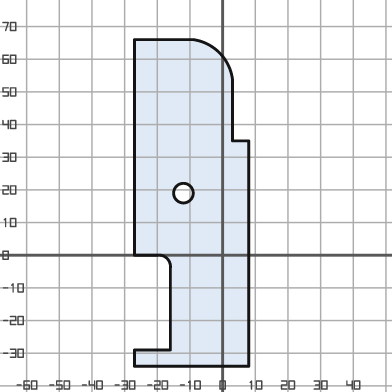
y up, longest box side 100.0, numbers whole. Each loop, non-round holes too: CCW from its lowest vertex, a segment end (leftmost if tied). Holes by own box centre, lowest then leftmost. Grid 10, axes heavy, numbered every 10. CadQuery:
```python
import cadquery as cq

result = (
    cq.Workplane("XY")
    .moveTo(-27.0, -34.0)
    .lineTo(8.0, -34.0)
    .lineTo(8.0, 35.0)
    .lineTo(3.0, 35.0)
    .lineTo(3.0, 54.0)
    .threePointArc((-1.0, 62.0), (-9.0, 66.0))
    .lineTo(-27.0, 66.0)
    .lineTo(-27.0, 0.0)
    .lineTo(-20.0, 0.0)
    .threePointArc((-17.0, -1.0), (-16.0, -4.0))
    .lineTo(-16.0, -29.0)
    .lineTo(-27.0, -29.0)
    .close()
    .moveTo(-12.0, 19.0)
    .circle(3.0)
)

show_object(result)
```